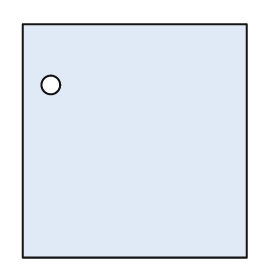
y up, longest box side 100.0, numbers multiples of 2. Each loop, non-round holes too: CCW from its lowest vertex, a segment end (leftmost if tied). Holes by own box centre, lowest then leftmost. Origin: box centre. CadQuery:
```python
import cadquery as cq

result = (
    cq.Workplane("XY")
    .moveTo(-48.0, -50.0)
    .lineTo(48.0, -50.0)
    .lineTo(48.0, 50.0)
    .lineTo(-48.0, 50.0)
    .close()
    .moveTo(-36.0, 24.0)
    .circle(4.0)
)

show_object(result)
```